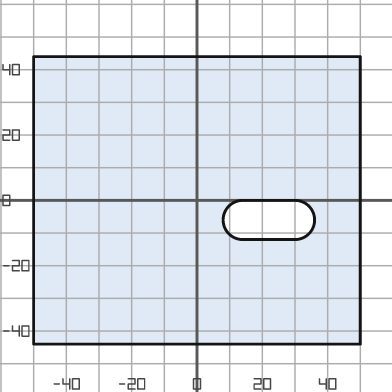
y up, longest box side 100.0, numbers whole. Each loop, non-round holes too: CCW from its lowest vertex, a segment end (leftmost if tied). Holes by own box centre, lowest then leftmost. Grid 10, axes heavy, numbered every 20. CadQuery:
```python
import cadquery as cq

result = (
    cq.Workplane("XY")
    .moveTo(-50.0, -44.0)
    .lineTo(50.0, -44.0)
    .lineTo(50.0, 44.0)
    .lineTo(-50.0, 44.0)
    .close()
    .moveTo(14.0, -12.0)
    .lineTo(30.0, -12.0)
    .threePointArc((36.0, -6.0), (30.0, 0.0))
    .lineTo(14.0, 0.0)
    .threePointArc((8.0, -6.0), (14.0, -12.0))
    .close()
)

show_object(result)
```